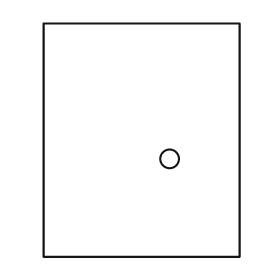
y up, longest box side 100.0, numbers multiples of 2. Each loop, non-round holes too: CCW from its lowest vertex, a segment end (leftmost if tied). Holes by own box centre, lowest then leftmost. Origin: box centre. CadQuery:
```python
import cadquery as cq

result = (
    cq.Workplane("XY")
    .moveTo(-42.0, -50.0)
    .lineTo(42.0, -50.0)
    .lineTo(42.0, 50.0)
    .lineTo(-42.0, 50.0)
    .close()
    .moveTo(12.0, -8.0)
    .circle(4.0)
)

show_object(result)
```